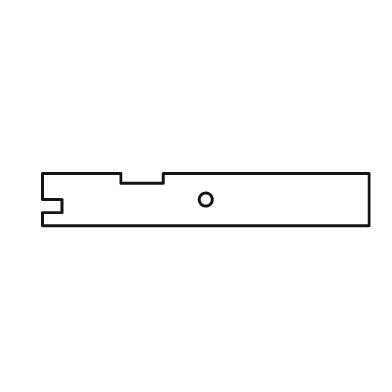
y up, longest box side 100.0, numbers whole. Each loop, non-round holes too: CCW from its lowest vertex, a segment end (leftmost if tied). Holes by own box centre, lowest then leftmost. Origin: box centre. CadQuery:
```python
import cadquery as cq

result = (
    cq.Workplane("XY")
    .moveTo(-50.0, -8.0)
    .lineTo(50.0, -8.0)
    .lineTo(50.0, 8.0)
    .lineTo(-13.0, 8.0)
    .lineTo(-13.0, 5.0)
    .lineTo(-26.0, 5.0)
    .lineTo(-26.0, 8.0)
    .lineTo(-50.0, 8.0)
    .lineTo(-50.0, 0.0)
    .lineTo(-44.0, 0.0)
    .lineTo(-44.0, -4.0)
    .lineTo(-50.0, -4.0)
    .close()
    .moveTo(0.0, 0.0)
    .circle(2.0)
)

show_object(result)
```